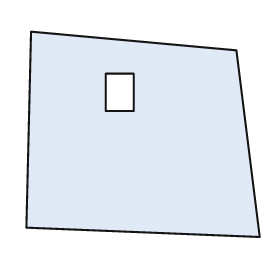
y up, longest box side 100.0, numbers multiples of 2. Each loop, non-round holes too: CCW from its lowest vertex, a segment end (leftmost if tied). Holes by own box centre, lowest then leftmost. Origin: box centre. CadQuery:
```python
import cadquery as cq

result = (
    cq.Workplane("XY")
    .moveTo(50.0, -44.0)
    .lineTo(40.0, 36.0)
    .lineTo(-48.0, 44.0)
    .lineTo(-50.0, -40.0)
    .close()
    .moveTo(-16.0, 10.0)
    .lineTo(-4.0, 10.0)
    .lineTo(-4.0, 26.0)
    .lineTo(-16.0, 26.0)
    .close()
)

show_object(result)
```